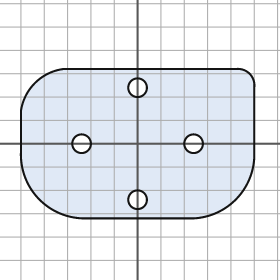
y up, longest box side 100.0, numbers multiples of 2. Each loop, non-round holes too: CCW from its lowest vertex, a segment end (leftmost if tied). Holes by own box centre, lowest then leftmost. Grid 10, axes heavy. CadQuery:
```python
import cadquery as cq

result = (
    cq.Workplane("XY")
    .moveTo(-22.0, -32.0)
    .lineTo(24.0, -32.0)
    .threePointArc((42.0, -24.0), (50.0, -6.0))
    .lineTo(50.0, 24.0)
    .threePointArc((48.0, 30.0), (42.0, 32.0))
    .lineTo(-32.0, 32.0)
    .threePointArc((-44.0, 26.0), (-50.0, 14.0))
    .lineTo(-50.0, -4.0)
    .threePointArc((-42.0, -24.0), (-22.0, -32.0))
    .close()
    .moveTo(0.0, -24.0)
    .circle(4.0)
    .moveTo(-24.0, 0.0)
    .circle(4.0)
    .moveTo(24.0, 0.0)
    .circle(4.0)
    .moveTo(0.0, 24.0)
    .circle(4.0)
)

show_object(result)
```